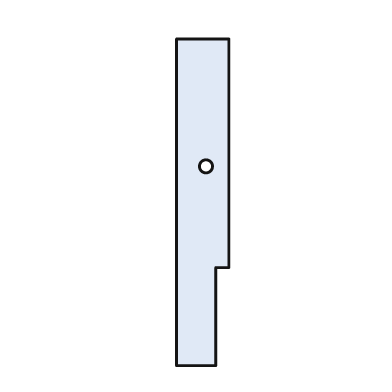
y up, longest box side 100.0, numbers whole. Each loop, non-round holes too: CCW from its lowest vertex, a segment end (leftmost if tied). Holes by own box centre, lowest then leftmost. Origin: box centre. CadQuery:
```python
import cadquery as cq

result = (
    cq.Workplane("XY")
    .moveTo(-8.0, -50.0)
    .lineTo(4.0, -50.0)
    .lineTo(4.0, -20.0)
    .lineTo(8.0, -20.0)
    .lineTo(8.0, 50.0)
    .lineTo(-8.0, 50.0)
    .close()
    .moveTo(1.0, 11.0)
    .circle(2.0)
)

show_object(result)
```